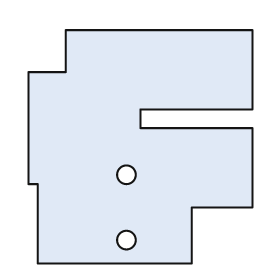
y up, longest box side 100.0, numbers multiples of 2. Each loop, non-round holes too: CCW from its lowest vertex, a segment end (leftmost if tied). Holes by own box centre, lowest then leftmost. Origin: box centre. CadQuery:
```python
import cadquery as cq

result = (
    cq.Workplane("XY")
    .moveTo(-44.0, -50.0)
    .lineTo(22.0, -50.0)
    .lineTo(22.0, -26.0)
    .lineTo(48.0, -26.0)
    .lineTo(48.0, 8.0)
    .lineTo(0.0, 8.0)
    .lineTo(0.0, 16.0)
    .lineTo(48.0, 16.0)
    .lineTo(48.0, 50.0)
    .lineTo(-32.0, 50.0)
    .lineTo(-32.0, 32.0)
    .lineTo(-48.0, 32.0)
    .lineTo(-48.0, -16.0)
    .lineTo(-44.0, -16.0)
    .close()
    .moveTo(-6.0, -40.0)
    .circle(4.0)
    .moveTo(-6.0, -12.0)
    .circle(4.0)
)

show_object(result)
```